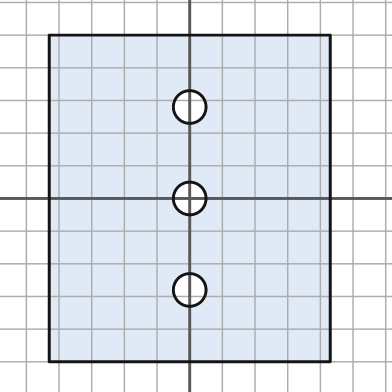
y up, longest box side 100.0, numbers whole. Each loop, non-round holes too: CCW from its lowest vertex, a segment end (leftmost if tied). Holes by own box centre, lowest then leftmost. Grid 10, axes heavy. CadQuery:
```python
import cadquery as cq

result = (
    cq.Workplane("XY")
    .moveTo(-43.0, -50.0)
    .lineTo(43.0, -50.0)
    .lineTo(43.0, 50.0)
    .lineTo(-43.0, 50.0)
    .close()
    .moveTo(0.0, -28.0)
    .circle(5.0)
    .moveTo(0.0, 0.0)
    .circle(5.0)
    .moveTo(0.0, 28.0)
    .circle(5.0)
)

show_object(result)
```